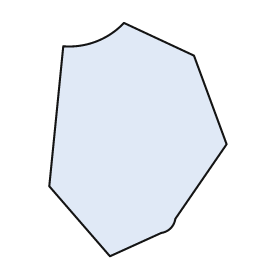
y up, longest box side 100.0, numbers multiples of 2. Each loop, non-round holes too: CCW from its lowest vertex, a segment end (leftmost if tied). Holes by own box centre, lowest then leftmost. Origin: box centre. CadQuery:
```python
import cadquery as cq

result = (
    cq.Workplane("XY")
    .moveTo(-12.0, -50.0)
    .lineTo(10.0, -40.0)
    .threePointArc((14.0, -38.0), (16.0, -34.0))
    .lineTo(38.0, -2.0)
    .lineTo(24.0, 36.0)
    .lineTo(-6.0, 50.0)
    .threePointArc((-18.0, 42.0), (-32.0, 40.0))
    .lineTo(-38.0, -20.0)
    .close()
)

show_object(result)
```